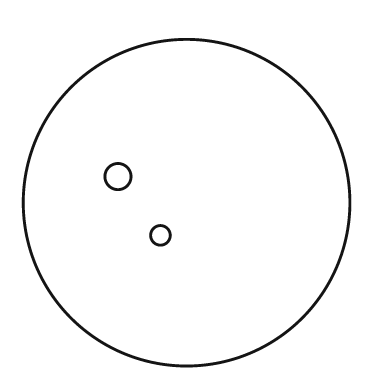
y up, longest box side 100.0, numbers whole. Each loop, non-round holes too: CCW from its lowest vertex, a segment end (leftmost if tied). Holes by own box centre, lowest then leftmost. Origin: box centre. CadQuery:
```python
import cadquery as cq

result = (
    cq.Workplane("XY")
    .moveTo(0.0, 0.0)
    .circle(50.0)
    .moveTo(-8.0, -10.0)
    .circle(3.0)
    .moveTo(-21.0, 8.0)
    .circle(4.0)
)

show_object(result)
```